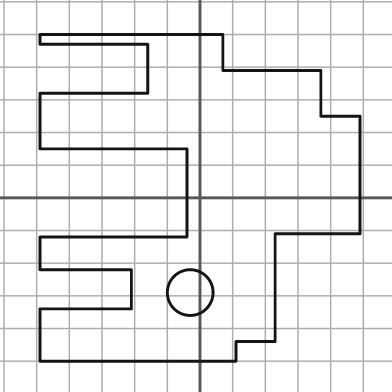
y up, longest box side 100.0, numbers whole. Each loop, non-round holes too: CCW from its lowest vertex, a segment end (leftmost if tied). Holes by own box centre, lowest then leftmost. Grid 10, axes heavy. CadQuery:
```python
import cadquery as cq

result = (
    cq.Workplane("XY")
    .moveTo(-49.0, -50.0)
    .lineTo(11.0, -50.0)
    .lineTo(11.0, -44.0)
    .lineTo(23.0, -44.0)
    .lineTo(23.0, -11.0)
    .lineTo(49.0, -11.0)
    .lineTo(49.0, 25.0)
    .lineTo(37.0, 25.0)
    .lineTo(37.0, 39.0)
    .lineTo(7.0, 39.0)
    .lineTo(7.0, 50.0)
    .lineTo(-49.0, 50.0)
    .lineTo(-49.0, 47.0)
    .lineTo(-16.0, 47.0)
    .lineTo(-16.0, 32.0)
    .lineTo(-49.0, 32.0)
    .lineTo(-49.0, 15.0)
    .lineTo(-4.0, 15.0)
    .lineTo(-4.0, -12.0)
    .lineTo(-49.0, -12.0)
    .lineTo(-49.0, -22.0)
    .lineTo(-21.0, -22.0)
    .lineTo(-21.0, -34.0)
    .lineTo(-49.0, -34.0)
    .close()
    .moveTo(-3.0, -29.0)
    .circle(7.0)
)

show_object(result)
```